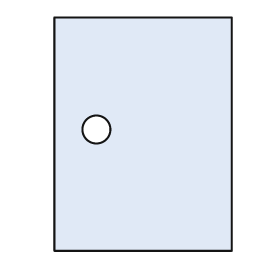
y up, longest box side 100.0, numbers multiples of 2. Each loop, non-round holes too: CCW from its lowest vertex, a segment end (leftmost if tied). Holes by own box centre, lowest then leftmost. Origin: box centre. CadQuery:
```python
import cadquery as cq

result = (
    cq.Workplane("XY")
    .moveTo(-38.0, -50.0)
    .lineTo(38.0, -50.0)
    .lineTo(38.0, 50.0)
    .lineTo(-38.0, 50.0)
    .close()
    .moveTo(-20.0, 2.0)
    .circle(6.0)
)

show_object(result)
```